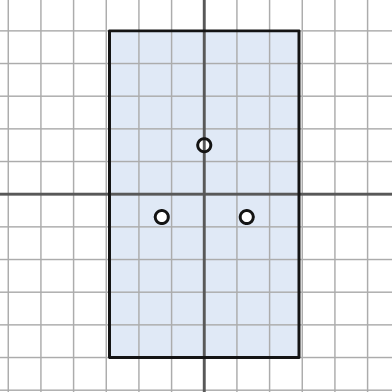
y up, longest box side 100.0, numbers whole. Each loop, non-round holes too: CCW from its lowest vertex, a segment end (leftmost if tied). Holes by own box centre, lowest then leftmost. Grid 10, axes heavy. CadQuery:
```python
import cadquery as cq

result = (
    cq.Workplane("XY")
    .moveTo(-29.0, -50.0)
    .lineTo(29.0, -50.0)
    .lineTo(29.0, 50.0)
    .lineTo(-29.0, 50.0)
    .close()
    .moveTo(-13.0, -7.0)
    .circle(2.0)
    .moveTo(13.0, -7.0)
    .circle(2.0)
    .moveTo(0.0, 15.0)
    .circle(2.0)
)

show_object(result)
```